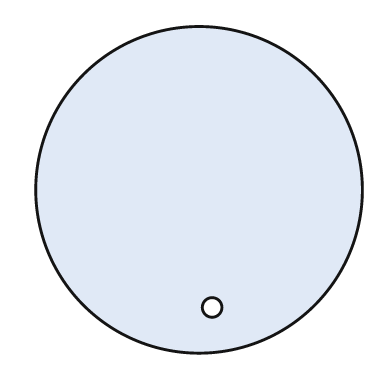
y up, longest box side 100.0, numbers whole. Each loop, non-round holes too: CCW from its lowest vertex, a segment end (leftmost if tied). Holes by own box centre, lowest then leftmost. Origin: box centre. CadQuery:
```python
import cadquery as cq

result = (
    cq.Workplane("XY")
    .moveTo(0.0, 0.0)
    .circle(50.0)
    .moveTo(4.0, -36.0)
    .circle(3.0)
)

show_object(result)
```